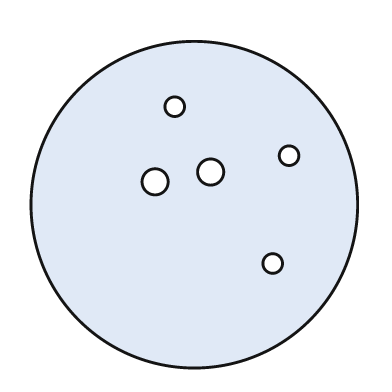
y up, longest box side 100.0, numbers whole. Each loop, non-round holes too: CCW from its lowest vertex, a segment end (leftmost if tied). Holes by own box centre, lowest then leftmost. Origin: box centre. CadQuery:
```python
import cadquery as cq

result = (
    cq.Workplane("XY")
    .moveTo(0.0, 0.0)
    .circle(50.0)
    .moveTo(24.0, -18.0)
    .circle(3.0)
    .moveTo(-12.0, 7.0)
    .circle(4.0)
    .moveTo(5.0, 10.0)
    .circle(4.0)
    .moveTo(29.0, 15.0)
    .circle(3.0)
    .moveTo(-6.0, 30.0)
    .circle(3.0)
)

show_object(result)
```